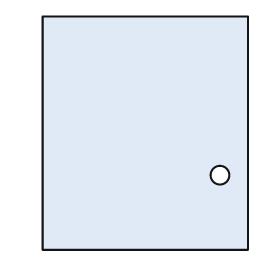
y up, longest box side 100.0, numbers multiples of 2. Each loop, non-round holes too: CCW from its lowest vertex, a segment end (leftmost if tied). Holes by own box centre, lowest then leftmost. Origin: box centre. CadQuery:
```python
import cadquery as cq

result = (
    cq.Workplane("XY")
    .moveTo(-44.0, -50.0)
    .lineTo(44.0, -50.0)
    .lineTo(44.0, 50.0)
    .lineTo(-44.0, 50.0)
    .close()
    .moveTo(32.0, -18.0)
    .circle(4.0)
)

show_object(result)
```